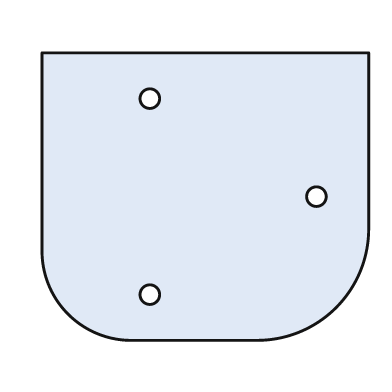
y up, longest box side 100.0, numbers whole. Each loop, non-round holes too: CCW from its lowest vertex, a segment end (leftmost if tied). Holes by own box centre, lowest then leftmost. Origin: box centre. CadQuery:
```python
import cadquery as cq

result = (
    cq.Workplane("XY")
    .moveTo(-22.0, -44.0)
    .lineTo(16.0, -44.0)
    .threePointArc((40.0, -34.0), (50.0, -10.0))
    .lineTo(50.0, 44.0)
    .lineTo(-50.0, 44.0)
    .lineTo(-50.0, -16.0)
    .threePointArc((-42.0, -36.0), (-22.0, -44.0))
    .close()
    .moveTo(-17.0, -30.0)
    .circle(3.0)
    .moveTo(34.0, 0.0)
    .circle(3.0)
    .moveTo(-17.0, 30.0)
    .circle(3.0)
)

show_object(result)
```